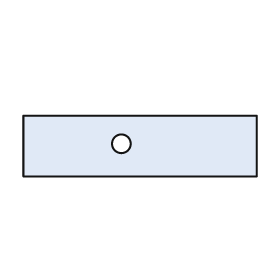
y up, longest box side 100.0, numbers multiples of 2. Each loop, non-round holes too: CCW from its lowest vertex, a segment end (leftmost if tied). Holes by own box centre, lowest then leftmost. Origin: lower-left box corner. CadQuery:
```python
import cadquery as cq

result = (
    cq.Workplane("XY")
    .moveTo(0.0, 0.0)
    .lineTo(100.0, 0.0)
    .lineTo(100.0, 26.0)
    .lineTo(0.0, 26.0)
    .close()
    .moveTo(42.0, 14.0)
    .circle(4.0)
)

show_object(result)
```